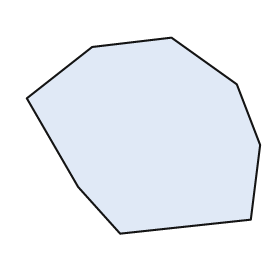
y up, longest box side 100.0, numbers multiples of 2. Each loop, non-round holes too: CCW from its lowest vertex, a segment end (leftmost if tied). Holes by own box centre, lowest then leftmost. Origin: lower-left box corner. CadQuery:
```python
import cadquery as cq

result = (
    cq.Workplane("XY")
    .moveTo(40.0, 0.0)
    .lineTo(96.0, 6.0)
    .lineTo(100.0, 38.0)
    .lineTo(90.0, 64.0)
    .lineTo(62.0, 84.0)
    .lineTo(28.0, 80.0)
    .lineTo(0.0, 58.0)
    .lineTo(22.0, 20.0)
    .close()
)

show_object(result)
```